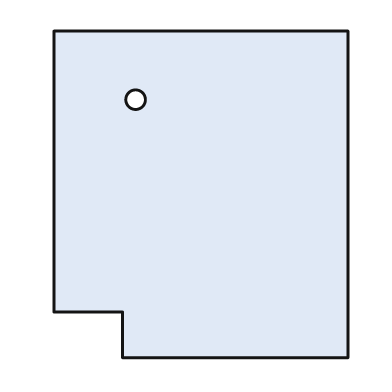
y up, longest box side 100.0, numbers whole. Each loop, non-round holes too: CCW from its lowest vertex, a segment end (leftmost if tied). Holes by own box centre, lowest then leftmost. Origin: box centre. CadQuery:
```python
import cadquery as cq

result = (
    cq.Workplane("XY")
    .moveTo(-24.0, -50.0)
    .lineTo(45.0, -50.0)
    .lineTo(45.0, 50.0)
    .lineTo(-45.0, 50.0)
    .lineTo(-45.0, -36.0)
    .lineTo(-24.0, -36.0)
    .close()
    .moveTo(-20.0, 29.0)
    .circle(3.0)
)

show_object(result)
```